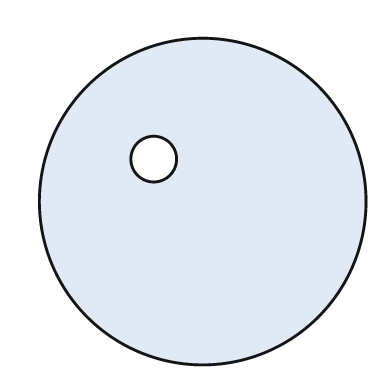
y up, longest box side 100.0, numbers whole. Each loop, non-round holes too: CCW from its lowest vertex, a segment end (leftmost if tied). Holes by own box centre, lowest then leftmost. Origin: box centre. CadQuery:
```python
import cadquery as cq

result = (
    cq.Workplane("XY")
    .moveTo(0.0, 0.0)
    .circle(50.0)
    .moveTo(-15.0, 13.0)
    .circle(7.0)
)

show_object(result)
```